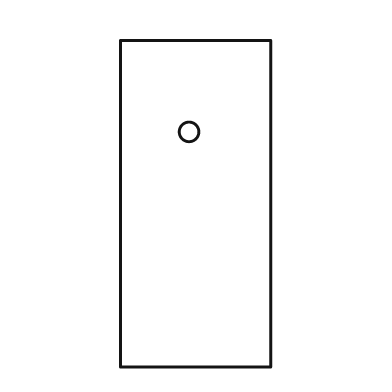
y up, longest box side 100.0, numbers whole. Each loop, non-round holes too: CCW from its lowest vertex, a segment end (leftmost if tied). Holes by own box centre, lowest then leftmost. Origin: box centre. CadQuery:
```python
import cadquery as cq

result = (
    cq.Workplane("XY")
    .moveTo(-23.0, -50.0)
    .lineTo(23.0, -50.0)
    .lineTo(23.0, 50.0)
    .lineTo(-23.0, 50.0)
    .close()
    .moveTo(-2.0, 22.0)
    .circle(3.0)
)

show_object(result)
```